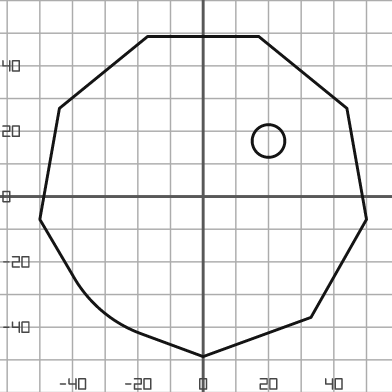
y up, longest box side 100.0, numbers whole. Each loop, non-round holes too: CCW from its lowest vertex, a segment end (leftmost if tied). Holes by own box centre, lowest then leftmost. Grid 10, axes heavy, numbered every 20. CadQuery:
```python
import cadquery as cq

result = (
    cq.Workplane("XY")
    .moveTo(0.0, -49.0)
    .lineTo(33.0, -37.0)
    .lineTo(50.0, -7.0)
    .lineTo(44.0, 27.0)
    .lineTo(17.0, 49.0)
    .lineTo(-17.0, 49.0)
    .lineTo(-44.0, 27.0)
    .lineTo(-50.0, -7.0)
    .lineTo(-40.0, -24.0)
    .threePointArc((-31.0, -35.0), (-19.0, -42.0))
    .close()
    .moveTo(20.0, 17.0)
    .circle(5.0)
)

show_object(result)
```